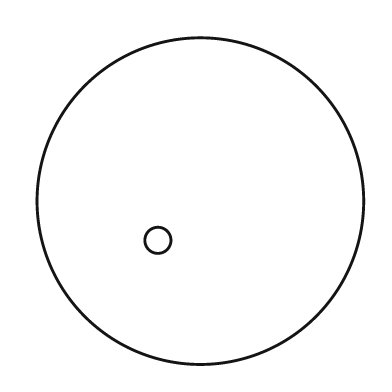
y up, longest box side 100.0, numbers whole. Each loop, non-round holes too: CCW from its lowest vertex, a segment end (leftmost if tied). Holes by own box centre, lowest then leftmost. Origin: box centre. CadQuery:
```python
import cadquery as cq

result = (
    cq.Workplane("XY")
    .moveTo(0.0, 0.0)
    .circle(50.0)
    .moveTo(-13.0, -12.0)
    .circle(4.0)
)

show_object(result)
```